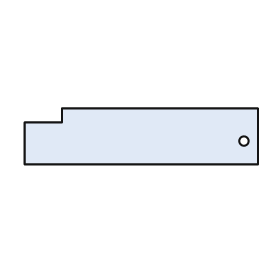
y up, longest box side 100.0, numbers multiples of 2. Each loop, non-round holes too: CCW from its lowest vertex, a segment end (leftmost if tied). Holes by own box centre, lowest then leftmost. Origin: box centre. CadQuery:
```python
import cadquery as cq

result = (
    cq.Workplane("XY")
    .moveTo(-50.0, -12.0)
    .lineTo(50.0, -12.0)
    .lineTo(50.0, 12.0)
    .lineTo(-34.0, 12.0)
    .lineTo(-34.0, 6.0)
    .lineTo(-50.0, 6.0)
    .close()
    .moveTo(44.0, -2.0)
    .circle(2.0)
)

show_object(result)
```